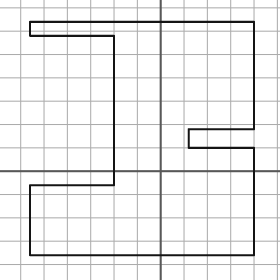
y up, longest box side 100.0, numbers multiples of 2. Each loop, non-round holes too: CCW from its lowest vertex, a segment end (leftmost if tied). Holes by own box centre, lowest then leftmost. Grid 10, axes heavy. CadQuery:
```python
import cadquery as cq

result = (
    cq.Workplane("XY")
    .moveTo(-56.0, -36.0)
    .lineTo(40.0, -36.0)
    .lineTo(40.0, 10.0)
    .lineTo(12.0, 10.0)
    .lineTo(12.0, 18.0)
    .lineTo(40.0, 18.0)
    .lineTo(40.0, 64.0)
    .lineTo(-56.0, 64.0)
    .lineTo(-56.0, 58.0)
    .lineTo(-20.0, 58.0)
    .lineTo(-20.0, -6.0)
    .lineTo(-56.0, -6.0)
    .close()
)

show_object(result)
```